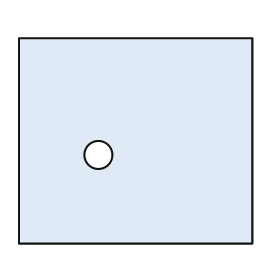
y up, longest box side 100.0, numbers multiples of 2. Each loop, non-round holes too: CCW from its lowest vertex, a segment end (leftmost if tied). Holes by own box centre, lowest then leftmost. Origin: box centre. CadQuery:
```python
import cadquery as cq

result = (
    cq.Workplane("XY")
    .moveTo(-50.0, -44.0)
    .lineTo(50.0, -44.0)
    .lineTo(50.0, 44.0)
    .lineTo(-50.0, 44.0)
    .close()
    .moveTo(-16.0, -6.0)
    .circle(6.0)
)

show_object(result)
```